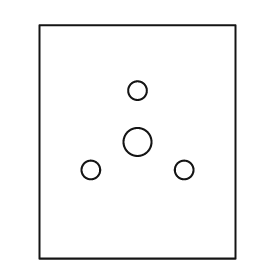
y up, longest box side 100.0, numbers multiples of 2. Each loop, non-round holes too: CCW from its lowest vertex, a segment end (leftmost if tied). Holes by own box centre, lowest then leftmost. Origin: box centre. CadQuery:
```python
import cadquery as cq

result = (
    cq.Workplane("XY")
    .moveTo(-42.0, -50.0)
    .lineTo(42.0, -50.0)
    .lineTo(42.0, 50.0)
    .lineTo(-42.0, 50.0)
    .close()
    .moveTo(-20.0, -12.0)
    .circle(4.0)
    .moveTo(20.0, -12.0)
    .circle(4.0)
    .moveTo(0.0, 0.0)
    .circle(6.0)
    .moveTo(0.0, 22.0)
    .circle(4.0)
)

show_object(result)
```